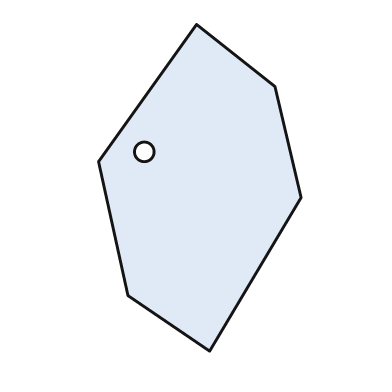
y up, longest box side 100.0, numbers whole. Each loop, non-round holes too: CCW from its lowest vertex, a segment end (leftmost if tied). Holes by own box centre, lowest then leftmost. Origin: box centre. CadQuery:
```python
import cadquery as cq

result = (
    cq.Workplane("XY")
    .moveTo(3.0, -50.0)
    .lineTo(31.0, -3.0)
    .lineTo(23.0, 31.0)
    .lineTo(-1.0, 50.0)
    .lineTo(-31.0, 8.0)
    .lineTo(-22.0, -33.0)
    .close()
    .moveTo(-17.0, 11.0)
    .circle(3.0)
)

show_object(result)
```